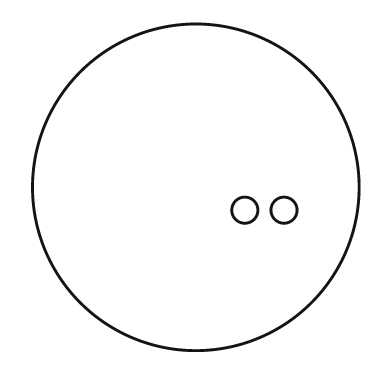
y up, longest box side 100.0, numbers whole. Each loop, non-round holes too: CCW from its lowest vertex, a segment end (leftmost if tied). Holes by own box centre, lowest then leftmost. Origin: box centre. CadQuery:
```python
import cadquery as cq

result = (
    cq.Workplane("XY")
    .moveTo(0.0, 0.0)
    .circle(50.0)
    .moveTo(15.0, -7.0)
    .circle(4.0)
    .moveTo(27.0, -7.0)
    .circle(4.0)
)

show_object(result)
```